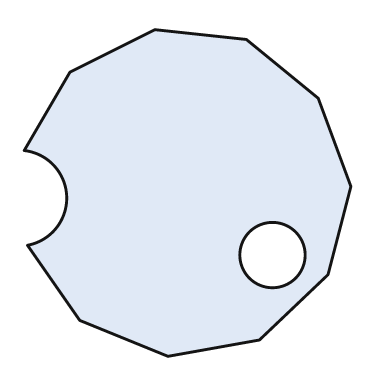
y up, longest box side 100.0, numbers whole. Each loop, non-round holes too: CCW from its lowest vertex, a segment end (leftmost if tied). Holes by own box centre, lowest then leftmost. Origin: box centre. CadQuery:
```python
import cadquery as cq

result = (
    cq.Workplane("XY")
    .moveTo(-6.0, -50.0)
    .lineTo(22.0, -45.0)
    .lineTo(43.0, -25.0)
    .lineTo(50.0, 2.0)
    .lineTo(40.0, 29.0)
    .lineTo(18.0, 47.0)
    .lineTo(-10.0, 50.0)
    .lineTo(-36.0, 37.0)
    .lineTo(-50.0, 13.0)
    .threePointArc((-37.0, -1.0), (-49.0, -16.0))
    .lineTo(-33.0, -39.0)
    .close()
    .moveTo(26.0, -19.0)
    .circle(10.0)
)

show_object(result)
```